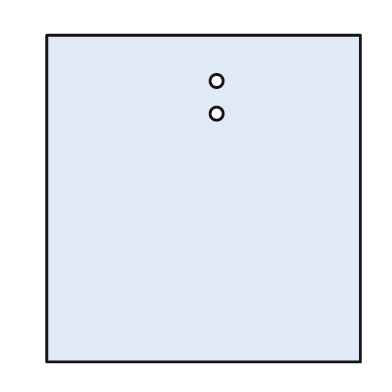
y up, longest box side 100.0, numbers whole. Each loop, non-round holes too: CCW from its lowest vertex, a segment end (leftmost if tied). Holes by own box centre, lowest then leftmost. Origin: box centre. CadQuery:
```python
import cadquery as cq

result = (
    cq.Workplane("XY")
    .moveTo(-48.0, -50.0)
    .lineTo(48.0, -50.0)
    .lineTo(48.0, 50.0)
    .lineTo(-48.0, 50.0)
    .close()
    .moveTo(4.0, 26.0)
    .circle(2.0)
    .moveTo(4.0, 36.0)
    .circle(2.0)
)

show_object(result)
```